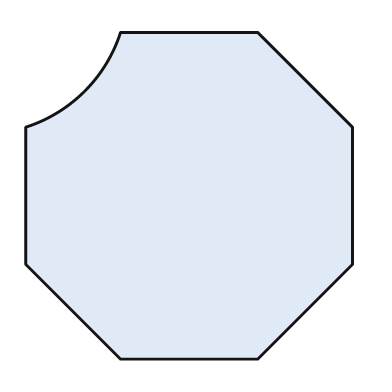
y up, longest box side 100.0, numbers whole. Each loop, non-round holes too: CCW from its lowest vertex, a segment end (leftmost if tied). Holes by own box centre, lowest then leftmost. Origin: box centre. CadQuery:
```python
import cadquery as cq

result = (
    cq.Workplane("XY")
    .moveTo(-21.0, -50.0)
    .lineTo(21.0, -50.0)
    .lineTo(50.0, -21.0)
    .lineTo(50.0, 21.0)
    .lineTo(21.0, 50.0)
    .lineTo(-21.0, 50.0)
    .threePointArc((-32.0, 32.0), (-50.0, 21.0))
    .lineTo(-50.0, -21.0)
    .close()
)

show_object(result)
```